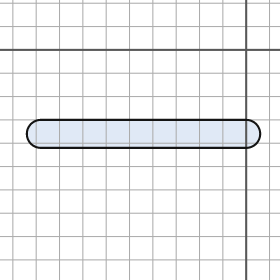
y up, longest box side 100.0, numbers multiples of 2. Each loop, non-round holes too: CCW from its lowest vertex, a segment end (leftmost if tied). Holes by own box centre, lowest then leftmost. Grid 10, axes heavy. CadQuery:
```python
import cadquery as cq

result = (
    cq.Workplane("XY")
    .moveTo(-88.0, -42.0)
    .lineTo(0.0, -42.0)
    .threePointArc((6.0, -36.0), (0.0, -30.0))
    .lineTo(-88.0, -30.0)
    .threePointArc((-94.0, -36.0), (-88.0, -42.0))
    .close()
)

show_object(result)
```